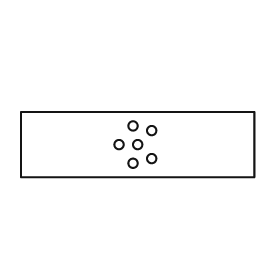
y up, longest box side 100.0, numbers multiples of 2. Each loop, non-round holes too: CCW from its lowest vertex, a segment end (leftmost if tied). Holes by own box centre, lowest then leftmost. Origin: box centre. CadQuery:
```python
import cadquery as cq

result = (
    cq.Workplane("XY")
    .moveTo(-50.0, -14.0)
    .lineTo(50.0, -14.0)
    .lineTo(50.0, 14.0)
    .lineTo(-50.0, 14.0)
    .close()
    .moveTo(-2.0, -8.0)
    .circle(2.0)
    .moveTo(6.0, -6.0)
    .circle(2.0)
    .moveTo(-8.0, 0.0)
    .circle(2.0)
    .moveTo(0.0, 0.0)
    .circle(2.0)
    .moveTo(6.0, 6.0)
    .circle(2.0)
    .moveTo(-2.0, 8.0)
    .circle(2.0)
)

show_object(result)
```